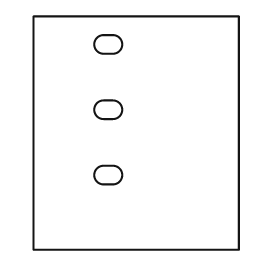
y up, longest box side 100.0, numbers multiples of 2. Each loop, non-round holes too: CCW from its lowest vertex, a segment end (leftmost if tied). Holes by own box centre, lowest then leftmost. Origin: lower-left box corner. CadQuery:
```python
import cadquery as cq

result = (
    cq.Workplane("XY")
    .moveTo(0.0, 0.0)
    .lineTo(88.0, 0.0)
    .lineTo(88.0, 100.0)
    .lineTo(0.0, 100.0)
    .close()
    .moveTo(30.0, 28.0)
    .lineTo(34.0, 28.0)
    .threePointArc((38.0, 32.0), (34.0, 36.0))
    .lineTo(30.0, 36.0)
    .threePointArc((26.0, 32.0), (30.0, 28.0))
    .close()
    .moveTo(30.0, 56.0)
    .lineTo(34.0, 56.0)
    .threePointArc((38.0, 60.0), (34.0, 64.0))
    .lineTo(30.0, 64.0)
    .threePointArc((26.0, 60.0), (30.0, 56.0))
    .close()
    .moveTo(30.0, 84.0)
    .lineTo(34.0, 84.0)
    .threePointArc((38.0, 88.0), (34.0, 92.0))
    .lineTo(30.0, 92.0)
    .threePointArc((26.0, 88.0), (30.0, 84.0))
    .close()
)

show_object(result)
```